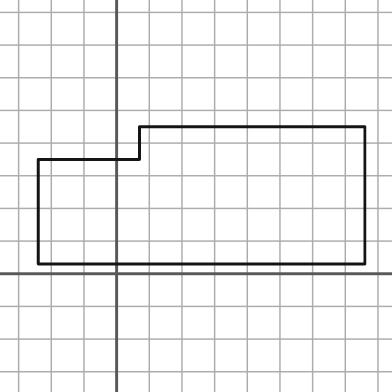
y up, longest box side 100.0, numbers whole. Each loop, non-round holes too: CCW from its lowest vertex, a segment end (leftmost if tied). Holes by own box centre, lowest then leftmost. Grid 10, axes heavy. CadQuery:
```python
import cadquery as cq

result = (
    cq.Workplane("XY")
    .moveTo(-24.0, 3.0)
    .lineTo(76.0, 3.0)
    .lineTo(76.0, 45.0)
    .lineTo(7.0, 45.0)
    .lineTo(7.0, 35.0)
    .lineTo(-24.0, 35.0)
    .close()
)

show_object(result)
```